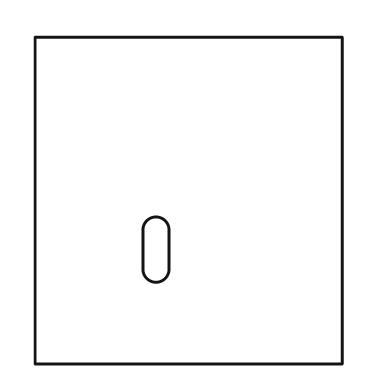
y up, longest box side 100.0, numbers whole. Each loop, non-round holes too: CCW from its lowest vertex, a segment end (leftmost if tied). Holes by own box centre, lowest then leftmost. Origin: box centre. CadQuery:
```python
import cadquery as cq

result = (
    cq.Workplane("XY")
    .moveTo(-47.0, -50.0)
    .lineTo(47.0, -50.0)
    .lineTo(47.0, 50.0)
    .lineTo(-47.0, 50.0)
    .close()
    .moveTo(-14.0, -21.0)
    .threePointArc((-10.0, -25.0), (-6.0, -21.0))
    .lineTo(-6.0, -9.0)
    .threePointArc((-10.0, -5.0), (-14.0, -9.0))
    .close()
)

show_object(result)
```